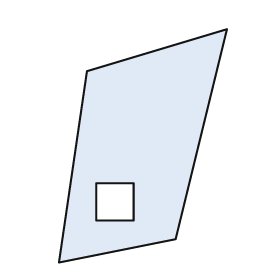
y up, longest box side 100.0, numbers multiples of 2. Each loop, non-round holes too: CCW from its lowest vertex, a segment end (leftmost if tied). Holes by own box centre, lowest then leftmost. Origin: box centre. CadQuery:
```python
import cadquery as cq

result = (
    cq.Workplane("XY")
    .moveTo(-36.0, -50.0)
    .lineTo(14.0, -40.0)
    .lineTo(36.0, 50.0)
    .lineTo(-24.0, 32.0)
    .close()
    .moveTo(-20.0, -32.0)
    .lineTo(-4.0, -32.0)
    .lineTo(-4.0, -16.0)
    .lineTo(-20.0, -16.0)
    .close()
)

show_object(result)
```